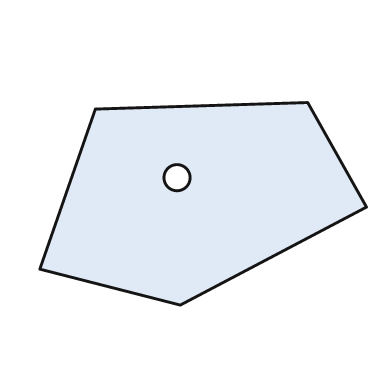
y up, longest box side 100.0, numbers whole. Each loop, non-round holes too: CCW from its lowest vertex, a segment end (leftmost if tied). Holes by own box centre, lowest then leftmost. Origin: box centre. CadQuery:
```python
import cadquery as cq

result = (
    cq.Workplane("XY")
    .moveTo(-7.0, -31.0)
    .lineTo(50.0, -1.0)
    .lineTo(32.0, 31.0)
    .lineTo(-33.0, 29.0)
    .lineTo(-50.0, -20.0)
    .close()
    .moveTo(-8.0, 8.0)
    .circle(4.0)
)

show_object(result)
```